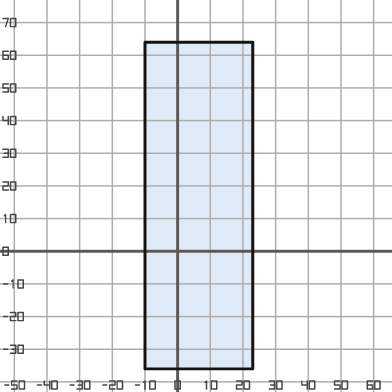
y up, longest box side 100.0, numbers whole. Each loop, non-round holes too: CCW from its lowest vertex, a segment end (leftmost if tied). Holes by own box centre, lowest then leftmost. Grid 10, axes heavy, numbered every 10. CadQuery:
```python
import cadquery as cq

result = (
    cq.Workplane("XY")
    .moveTo(-10.0, -36.0)
    .lineTo(23.0, -36.0)
    .lineTo(23.0, 64.0)
    .lineTo(-10.0, 64.0)
    .close()
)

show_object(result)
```